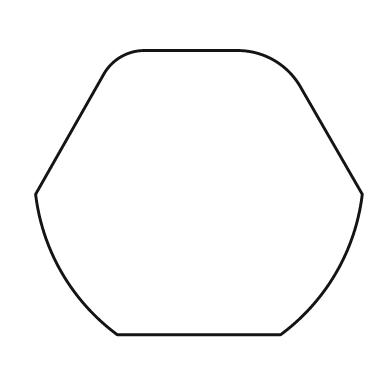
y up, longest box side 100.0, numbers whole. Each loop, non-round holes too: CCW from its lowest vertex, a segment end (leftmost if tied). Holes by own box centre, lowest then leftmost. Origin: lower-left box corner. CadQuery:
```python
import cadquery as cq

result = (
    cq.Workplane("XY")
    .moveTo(25.0, 0.0)
    .lineTo(75.0, 0.0)
    .threePointArc((92.0, 19.0), (100.0, 43.0))
    .lineTo(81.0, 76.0)
    .threePointArc((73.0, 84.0), (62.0, 87.0))
    .lineTo(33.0, 87.0)
    .threePointArc((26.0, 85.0), (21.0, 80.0))
    .lineTo(0.0, 43.0)
    .threePointArc((8.0, 19.0), (25.0, 0.0))
    .close()
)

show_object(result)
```